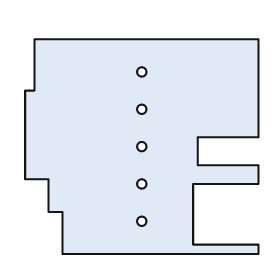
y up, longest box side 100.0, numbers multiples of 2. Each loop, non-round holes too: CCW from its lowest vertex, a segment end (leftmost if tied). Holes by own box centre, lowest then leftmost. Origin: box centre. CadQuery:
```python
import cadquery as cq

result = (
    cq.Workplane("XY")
    .moveTo(-34.0, -46.0)
    .lineTo(50.0, -46.0)
    .lineTo(50.0, -42.0)
    .lineTo(22.0, -42.0)
    .lineTo(22.0, -16.0)
    .lineTo(50.0, -16.0)
    .lineTo(50.0, -8.0)
    .lineTo(24.0, -8.0)
    .lineTo(24.0, 4.0)
    .lineTo(50.0, 4.0)
    .lineTo(50.0, 46.0)
    .lineTo(-46.0, 46.0)
    .lineTo(-46.0, 24.0)
    .lineTo(-50.0, 24.0)
    .lineTo(-50.0, -14.0)
    .lineTo(-40.0, -14.0)
    .lineTo(-40.0, -28.0)
    .lineTo(-34.0, -28.0)
    .close()
    .moveTo(0.0, -32.0)
    .circle(2.0)
    .moveTo(0.0, -16.0)
    .circle(2.0)
    .moveTo(0.0, 0.0)
    .circle(2.0)
    .moveTo(0.0, 16.0)
    .circle(2.0)
    .moveTo(0.0, 32.0)
    .circle(2.0)
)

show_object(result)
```